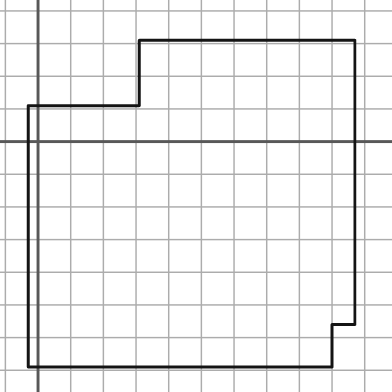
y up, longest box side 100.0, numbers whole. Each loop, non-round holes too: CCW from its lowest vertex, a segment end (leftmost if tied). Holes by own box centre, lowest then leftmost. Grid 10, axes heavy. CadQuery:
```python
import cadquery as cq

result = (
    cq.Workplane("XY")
    .moveTo(-3.0, -69.0)
    .lineTo(90.0, -69.0)
    .lineTo(90.0, -56.0)
    .lineTo(97.0, -56.0)
    .lineTo(97.0, 31.0)
    .lineTo(31.0, 31.0)
    .lineTo(31.0, 11.0)
    .lineTo(-3.0, 11.0)
    .close()
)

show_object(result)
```